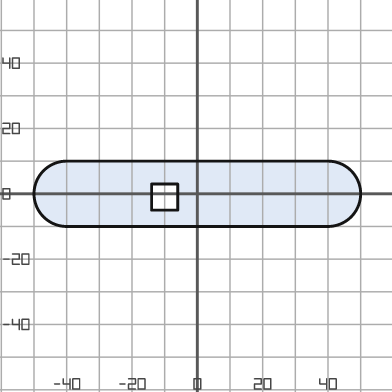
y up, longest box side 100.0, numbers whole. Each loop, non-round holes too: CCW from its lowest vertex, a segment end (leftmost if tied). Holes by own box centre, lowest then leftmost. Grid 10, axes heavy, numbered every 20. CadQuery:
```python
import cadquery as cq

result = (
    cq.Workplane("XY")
    .moveTo(-40.0, -10.0)
    .lineTo(40.0, -10.0)
    .threePointArc((50.0, 0.0), (40.0, 10.0))
    .lineTo(-40.0, 10.0)
    .threePointArc((-50.0, 0.0), (-40.0, -10.0))
    .close()
    .moveTo(-14.0, -5.0)
    .lineTo(-6.0, -5.0)
    .lineTo(-6.0, 3.0)
    .lineTo(-14.0, 3.0)
    .close()
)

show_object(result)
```